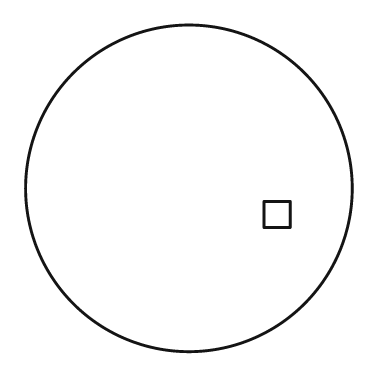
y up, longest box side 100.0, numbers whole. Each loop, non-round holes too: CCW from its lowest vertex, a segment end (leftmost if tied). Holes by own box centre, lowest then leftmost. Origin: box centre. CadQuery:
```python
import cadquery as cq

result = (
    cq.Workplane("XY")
    .moveTo(0.0, 0.0)
    .circle(50.0)
    .moveTo(23.0, -12.0)
    .lineTo(31.0, -12.0)
    .lineTo(31.0, -4.0)
    .lineTo(23.0, -4.0)
    .close()
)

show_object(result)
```